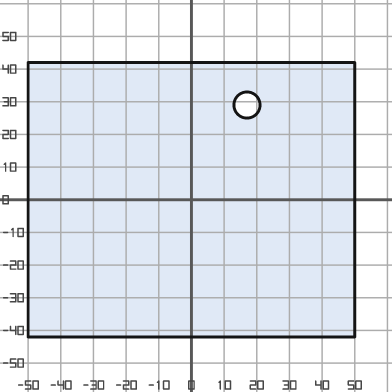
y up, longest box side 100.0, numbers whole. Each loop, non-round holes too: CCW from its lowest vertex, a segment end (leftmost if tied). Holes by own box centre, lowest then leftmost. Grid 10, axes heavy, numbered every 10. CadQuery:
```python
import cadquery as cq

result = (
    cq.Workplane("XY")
    .moveTo(-50.0, -42.0)
    .lineTo(50.0, -42.0)
    .lineTo(50.0, 42.0)
    .lineTo(-50.0, 42.0)
    .close()
    .moveTo(17.0, 29.0)
    .circle(4.0)
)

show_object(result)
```